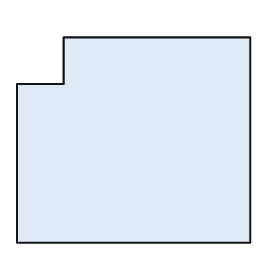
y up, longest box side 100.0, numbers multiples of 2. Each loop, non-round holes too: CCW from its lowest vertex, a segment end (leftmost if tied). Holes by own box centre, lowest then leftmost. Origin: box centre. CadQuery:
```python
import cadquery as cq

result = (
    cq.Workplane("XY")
    .moveTo(-50.0, -44.0)
    .lineTo(50.0, -44.0)
    .lineTo(50.0, 44.0)
    .lineTo(-30.0, 44.0)
    .lineTo(-30.0, 24.0)
    .lineTo(-50.0, 24.0)
    .close()
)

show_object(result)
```